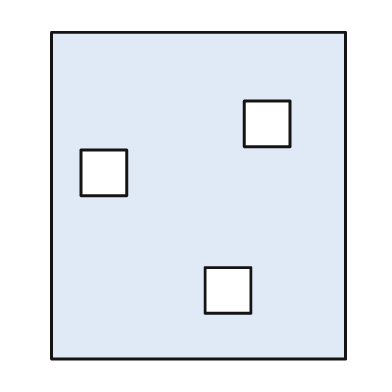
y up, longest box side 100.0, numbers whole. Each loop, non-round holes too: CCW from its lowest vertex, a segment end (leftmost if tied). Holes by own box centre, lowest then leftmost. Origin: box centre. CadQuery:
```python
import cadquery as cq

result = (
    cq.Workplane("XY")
    .moveTo(-45.0, -50.0)
    .lineTo(45.0, -50.0)
    .lineTo(45.0, 50.0)
    .lineTo(-45.0, 50.0)
    .close()
    .moveTo(2.0, -36.0)
    .lineTo(16.0, -36.0)
    .lineTo(16.0, -22.0)
    .lineTo(2.0, -22.0)
    .close()
    .moveTo(-36.0, 0.0)
    .lineTo(-22.0, 0.0)
    .lineTo(-22.0, 14.0)
    .lineTo(-36.0, 14.0)
    .close()
    .moveTo(14.0, 15.0)
    .lineTo(28.0, 15.0)
    .lineTo(28.0, 29.0)
    .lineTo(14.0, 29.0)
    .close()
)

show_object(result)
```